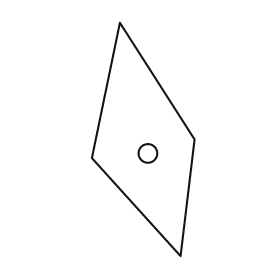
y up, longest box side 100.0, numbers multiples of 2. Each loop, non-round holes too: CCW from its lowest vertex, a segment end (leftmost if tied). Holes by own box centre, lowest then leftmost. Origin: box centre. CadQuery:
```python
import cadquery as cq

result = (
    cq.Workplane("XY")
    .moveTo(16.0, -50.0)
    .lineTo(22.0, 0.0)
    .lineTo(-10.0, 50.0)
    .lineTo(-22.0, -8.0)
    .close()
    .moveTo(2.0, -6.0)
    .circle(4.0)
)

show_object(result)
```